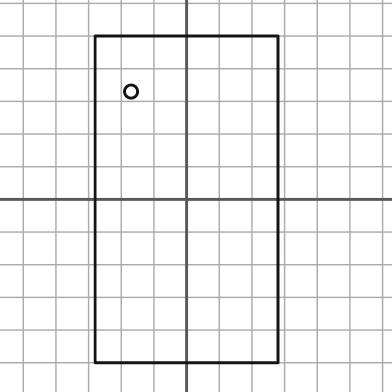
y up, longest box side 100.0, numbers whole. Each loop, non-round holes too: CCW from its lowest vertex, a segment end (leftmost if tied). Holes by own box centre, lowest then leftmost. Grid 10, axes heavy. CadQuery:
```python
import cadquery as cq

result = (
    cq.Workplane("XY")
    .moveTo(-28.0, -50.0)
    .lineTo(28.0, -50.0)
    .lineTo(28.0, 50.0)
    .lineTo(-28.0, 50.0)
    .close()
    .moveTo(-17.0, 33.0)
    .circle(2.0)
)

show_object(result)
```